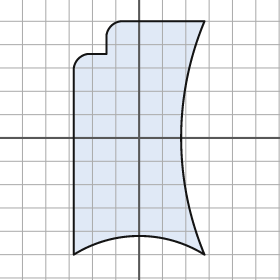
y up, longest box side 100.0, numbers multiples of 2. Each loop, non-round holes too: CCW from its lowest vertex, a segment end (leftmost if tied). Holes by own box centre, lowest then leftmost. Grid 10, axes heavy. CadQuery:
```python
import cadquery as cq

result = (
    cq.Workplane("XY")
    .moveTo(-28.0, -50.0)
    .threePointArc((0.0, -42.0), (28.0, -50.0))
    .threePointArc((18.0, 0.0), (28.0, 50.0))
    .lineTo(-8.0, 50.0)
    .threePointArc((-12.0, 48.0), (-14.0, 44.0))
    .lineTo(-14.0, 36.0)
    .lineTo(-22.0, 36.0)
    .threePointArc((-26.0, 34.0), (-28.0, 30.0))
    .close()
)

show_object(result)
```